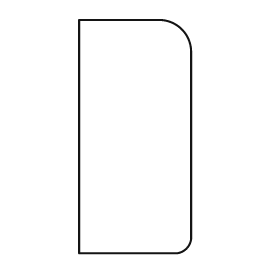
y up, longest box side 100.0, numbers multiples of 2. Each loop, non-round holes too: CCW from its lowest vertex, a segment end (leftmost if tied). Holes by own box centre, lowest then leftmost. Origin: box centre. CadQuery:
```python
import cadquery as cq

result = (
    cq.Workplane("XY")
    .moveTo(-24.0, -50.0)
    .lineTo(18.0, -50.0)
    .threePointArc((22.0, -48.0), (24.0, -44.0))
    .lineTo(24.0, 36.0)
    .threePointArc((20.0, 46.0), (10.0, 50.0))
    .lineTo(-24.0, 50.0)
    .close()
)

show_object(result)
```